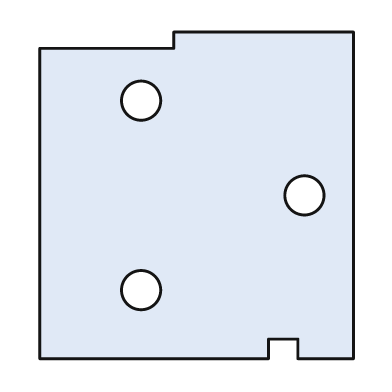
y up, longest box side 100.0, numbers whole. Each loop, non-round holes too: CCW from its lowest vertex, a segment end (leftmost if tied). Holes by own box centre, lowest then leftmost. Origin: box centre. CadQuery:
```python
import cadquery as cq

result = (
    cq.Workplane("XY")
    .moveTo(-48.0, -50.0)
    .lineTo(22.0, -50.0)
    .lineTo(22.0, -44.0)
    .lineTo(31.0, -44.0)
    .lineTo(31.0, -50.0)
    .lineTo(48.0, -50.0)
    .lineTo(48.0, 50.0)
    .lineTo(-7.0, 50.0)
    .lineTo(-7.0, 45.0)
    .lineTo(-48.0, 45.0)
    .close()
    .moveTo(-17.0, -29.0)
    .circle(6.0)
    .moveTo(33.0, 0.0)
    .circle(6.0)
    .moveTo(-17.0, 29.0)
    .circle(6.0)
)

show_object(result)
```